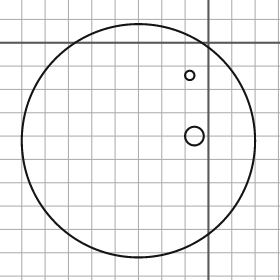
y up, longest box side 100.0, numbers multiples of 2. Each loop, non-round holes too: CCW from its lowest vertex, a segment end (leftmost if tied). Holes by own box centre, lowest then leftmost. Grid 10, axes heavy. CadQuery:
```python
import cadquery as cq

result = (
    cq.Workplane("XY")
    .moveTo(-30.0, -42.0)
    .circle(50.0)
    .moveTo(-6.0, -40.0)
    .circle(4.0)
    .moveTo(-8.0, -14.0)
    .circle(2.0)
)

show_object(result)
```